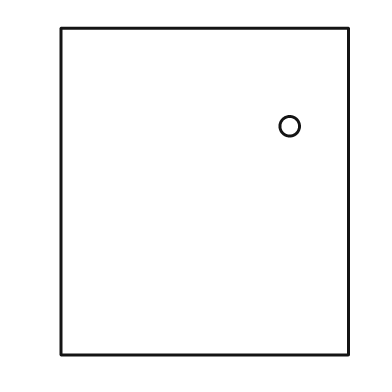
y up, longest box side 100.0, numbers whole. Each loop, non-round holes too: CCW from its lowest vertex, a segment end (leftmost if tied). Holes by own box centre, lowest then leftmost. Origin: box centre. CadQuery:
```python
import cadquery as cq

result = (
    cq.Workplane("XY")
    .moveTo(-44.0, -50.0)
    .lineTo(44.0, -50.0)
    .lineTo(44.0, 50.0)
    .lineTo(-44.0, 50.0)
    .close()
    .moveTo(26.0, 20.0)
    .circle(3.0)
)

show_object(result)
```